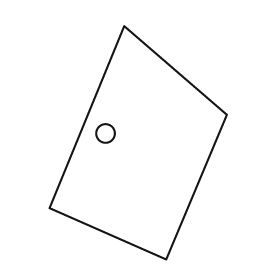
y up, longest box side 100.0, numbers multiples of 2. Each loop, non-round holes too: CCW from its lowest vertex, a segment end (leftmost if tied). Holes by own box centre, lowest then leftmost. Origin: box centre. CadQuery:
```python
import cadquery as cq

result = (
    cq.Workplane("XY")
    .moveTo(12.0, -50.0)
    .lineTo(38.0, 12.0)
    .lineTo(-6.0, 50.0)
    .lineTo(-38.0, -28.0)
    .close()
    .moveTo(-14.0, 4.0)
    .circle(4.0)
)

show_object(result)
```